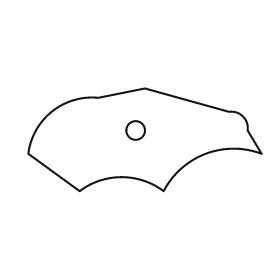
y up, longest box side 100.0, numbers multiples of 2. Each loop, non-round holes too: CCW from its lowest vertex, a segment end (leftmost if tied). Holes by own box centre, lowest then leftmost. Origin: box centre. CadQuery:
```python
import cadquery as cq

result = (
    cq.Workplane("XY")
    .moveTo(-28.0, -22.0)
    .threePointArc((-10.0, -16.0), (8.0, -22.0))
    .threePointArc((26.0, -6.0), (50.0, -6.0))
    .lineTo(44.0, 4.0)
    .threePointArc((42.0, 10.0), (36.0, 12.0))
    .lineTo(0.0, 22.0)
    .lineTo(-20.0, 18.0)
    .threePointArc((-40.0, 12.0), (-50.0, -6.0))
    .close()
    .moveTo(-4.0, 4.0)
    .circle(4.0)
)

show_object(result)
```